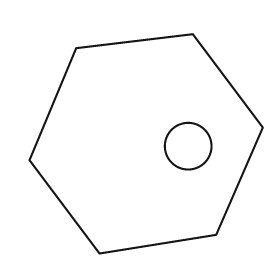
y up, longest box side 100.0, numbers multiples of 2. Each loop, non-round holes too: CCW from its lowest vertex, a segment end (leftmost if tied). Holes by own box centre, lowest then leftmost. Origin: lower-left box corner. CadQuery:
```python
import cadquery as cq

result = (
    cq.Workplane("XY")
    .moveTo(30.0, 0.0)
    .lineTo(80.0, 8.0)
    .lineTo(100.0, 54.0)
    .lineTo(70.0, 94.0)
    .lineTo(20.0, 88.0)
    .lineTo(0.0, 40.0)
    .close()
    .moveTo(68.0, 46.0)
    .circle(10.0)
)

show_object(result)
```